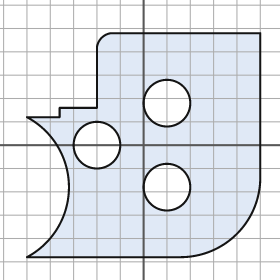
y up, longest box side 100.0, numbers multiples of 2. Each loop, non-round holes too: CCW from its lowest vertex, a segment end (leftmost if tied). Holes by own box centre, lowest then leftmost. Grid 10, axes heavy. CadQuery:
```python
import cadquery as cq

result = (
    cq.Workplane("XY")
    .moveTo(-50.0, -48.0)
    .lineTo(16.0, -48.0)
    .threePointArc((40.0, -38.0), (50.0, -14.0))
    .lineTo(50.0, 48.0)
    .lineTo(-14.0, 48.0)
    .threePointArc((-18.0, 46.0), (-20.0, 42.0))
    .lineTo(-20.0, 16.0)
    .lineTo(-36.0, 16.0)
    .lineTo(-36.0, 12.0)
    .lineTo(-50.0, 12.0)
    .threePointArc((-32.0, -18.0), (-50.0, -48.0))
    .close()
    .moveTo(10.0, -18.0)
    .circle(10.0)
    .moveTo(-20.0, 0.0)
    .circle(10.0)
    .moveTo(10.0, 18.0)
    .circle(10.0)
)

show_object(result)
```